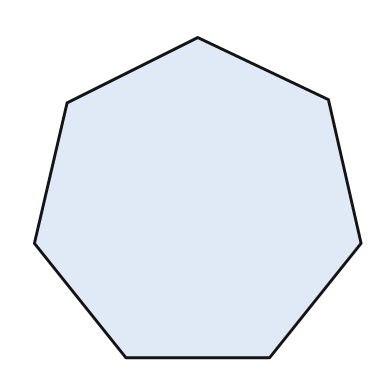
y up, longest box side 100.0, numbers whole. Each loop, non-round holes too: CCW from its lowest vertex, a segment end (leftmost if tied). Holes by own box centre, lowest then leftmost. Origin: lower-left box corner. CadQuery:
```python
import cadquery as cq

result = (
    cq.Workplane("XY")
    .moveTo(28.0, 0.0)
    .lineTo(72.0, 0.0)
    .lineTo(100.0, 35.0)
    .lineTo(90.0, 79.0)
    .lineTo(50.0, 98.0)
    .lineTo(10.0, 78.0)
    .lineTo(0.0, 35.0)
    .close()
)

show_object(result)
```